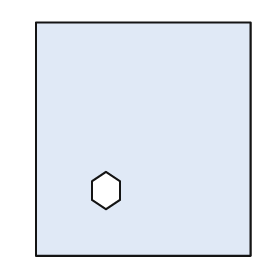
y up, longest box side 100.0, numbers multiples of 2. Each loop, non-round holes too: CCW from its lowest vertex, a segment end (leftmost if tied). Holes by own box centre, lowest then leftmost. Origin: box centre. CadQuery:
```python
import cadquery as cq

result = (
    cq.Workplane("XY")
    .moveTo(-46.0, -50.0)
    .lineTo(46.0, -50.0)
    .lineTo(46.0, 50.0)
    .lineTo(-46.0, 50.0)
    .close()
    .moveTo(-16.0, -30.0)
    .lineTo(-10.0, -26.0)
    .lineTo(-10.0, -18.0)
    .lineTo(-16.0, -14.0)
    .lineTo(-22.0, -18.0)
    .lineTo(-22.0, -26.0)
    .close()
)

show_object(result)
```